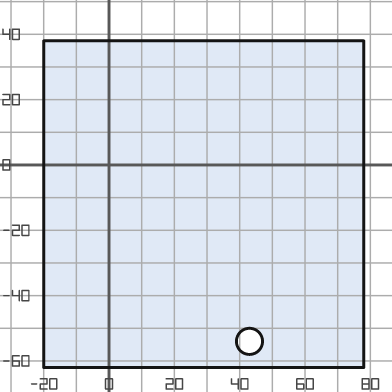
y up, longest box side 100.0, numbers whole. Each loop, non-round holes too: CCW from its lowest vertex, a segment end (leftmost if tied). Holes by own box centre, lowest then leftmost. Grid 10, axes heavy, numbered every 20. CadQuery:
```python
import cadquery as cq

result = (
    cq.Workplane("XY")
    .moveTo(-20.0, -62.0)
    .lineTo(78.0, -62.0)
    .lineTo(78.0, 38.0)
    .lineTo(-20.0, 38.0)
    .close()
    .moveTo(43.0, -54.0)
    .circle(4.0)
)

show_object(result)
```